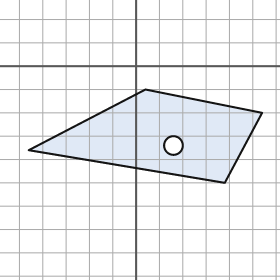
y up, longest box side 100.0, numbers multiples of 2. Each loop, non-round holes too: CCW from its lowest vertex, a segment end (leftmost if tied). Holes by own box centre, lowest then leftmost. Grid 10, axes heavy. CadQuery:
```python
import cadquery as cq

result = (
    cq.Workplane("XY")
    .moveTo(38.0, -50.0)
    .lineTo(54.0, -20.0)
    .lineTo(4.0, -10.0)
    .lineTo(-46.0, -36.0)
    .close()
    .moveTo(16.0, -34.0)
    .circle(4.0)
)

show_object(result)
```